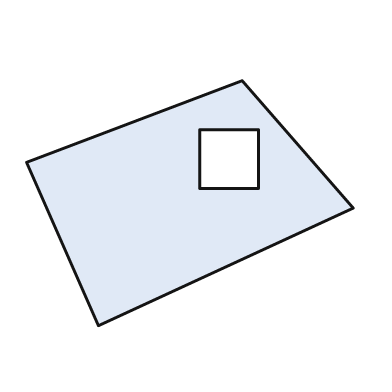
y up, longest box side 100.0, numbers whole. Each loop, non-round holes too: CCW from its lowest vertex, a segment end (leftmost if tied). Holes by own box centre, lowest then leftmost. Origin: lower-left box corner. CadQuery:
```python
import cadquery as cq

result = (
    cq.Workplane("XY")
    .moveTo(22.0, 0.0)
    .lineTo(100.0, 36.0)
    .lineTo(66.0, 75.0)
    .lineTo(0.0, 50.0)
    .close()
    .moveTo(53.0, 42.0)
    .lineTo(71.0, 42.0)
    .lineTo(71.0, 60.0)
    .lineTo(53.0, 60.0)
    .close()
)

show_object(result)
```